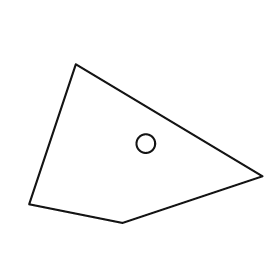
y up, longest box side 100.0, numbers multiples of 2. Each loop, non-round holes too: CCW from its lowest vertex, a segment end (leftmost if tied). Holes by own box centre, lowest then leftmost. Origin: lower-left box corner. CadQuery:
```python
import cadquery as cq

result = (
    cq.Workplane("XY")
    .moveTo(40.0, 0.0)
    .lineTo(100.0, 20.0)
    .lineTo(20.0, 68.0)
    .lineTo(0.0, 8.0)
    .close()
    .moveTo(50.0, 34.0)
    .circle(4.0)
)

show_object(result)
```